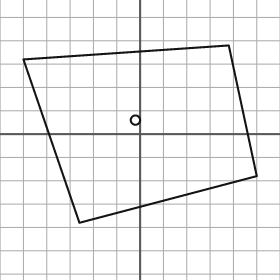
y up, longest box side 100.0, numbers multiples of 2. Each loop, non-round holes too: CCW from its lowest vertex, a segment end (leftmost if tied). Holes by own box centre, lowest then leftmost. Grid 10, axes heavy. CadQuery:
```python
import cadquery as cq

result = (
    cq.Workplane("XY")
    .moveTo(-26.0, -38.0)
    .lineTo(50.0, -18.0)
    .lineTo(38.0, 38.0)
    .lineTo(-50.0, 32.0)
    .close()
    .moveTo(-2.0, 6.0)
    .circle(2.0)
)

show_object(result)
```